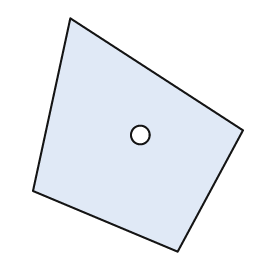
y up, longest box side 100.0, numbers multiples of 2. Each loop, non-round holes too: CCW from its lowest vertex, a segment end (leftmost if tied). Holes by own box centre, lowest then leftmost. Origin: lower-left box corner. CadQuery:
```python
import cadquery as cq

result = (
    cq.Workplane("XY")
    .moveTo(62.0, 0.0)
    .lineTo(90.0, 52.0)
    .lineTo(16.0, 100.0)
    .lineTo(0.0, 26.0)
    .close()
    .moveTo(46.0, 50.0)
    .circle(4.0)
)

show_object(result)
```